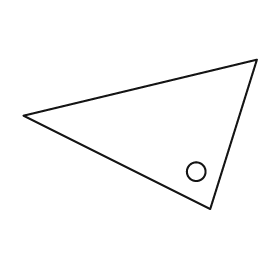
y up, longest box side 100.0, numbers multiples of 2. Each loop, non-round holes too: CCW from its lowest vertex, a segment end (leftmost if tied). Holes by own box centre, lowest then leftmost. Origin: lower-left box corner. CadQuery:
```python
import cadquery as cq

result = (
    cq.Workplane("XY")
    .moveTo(80.0, 0.0)
    .lineTo(100.0, 64.0)
    .lineTo(0.0, 40.0)
    .close()
    .moveTo(74.0, 16.0)
    .circle(4.0)
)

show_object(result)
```